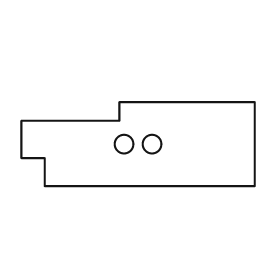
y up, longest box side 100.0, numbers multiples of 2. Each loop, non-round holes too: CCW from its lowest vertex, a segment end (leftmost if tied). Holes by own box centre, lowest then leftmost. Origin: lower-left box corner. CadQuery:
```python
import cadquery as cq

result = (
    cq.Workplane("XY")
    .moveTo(10.0, 0.0)
    .lineTo(100.0, 0.0)
    .lineTo(100.0, 36.0)
    .lineTo(42.0, 36.0)
    .lineTo(42.0, 28.0)
    .lineTo(0.0, 28.0)
    .lineTo(0.0, 12.0)
    .lineTo(10.0, 12.0)
    .close()
    .moveTo(44.0, 18.0)
    .circle(4.0)
    .moveTo(56.0, 18.0)
    .circle(4.0)
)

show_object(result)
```